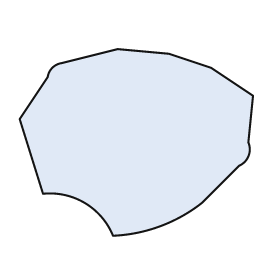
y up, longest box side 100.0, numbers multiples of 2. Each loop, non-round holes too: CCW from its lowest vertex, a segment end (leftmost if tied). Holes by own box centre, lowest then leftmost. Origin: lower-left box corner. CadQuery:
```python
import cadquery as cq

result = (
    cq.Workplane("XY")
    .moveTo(40.0, 0.0)
    .threePointArc((60.0, 4.0), (78.0, 14.0))
    .lineTo(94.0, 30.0)
    .threePointArc((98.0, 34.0), (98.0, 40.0))
    .lineTo(100.0, 60.0)
    .lineTo(82.0, 72.0)
    .lineTo(64.0, 78.0)
    .lineTo(42.0, 80.0)
    .lineTo(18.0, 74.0)
    .threePointArc((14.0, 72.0), (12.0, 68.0))
    .lineTo(0.0, 50.0)
    .lineTo(10.0, 18.0)
    .threePointArc((28.0, 14.0), (40.0, 0.0))
    .close()
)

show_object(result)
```